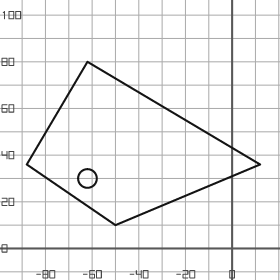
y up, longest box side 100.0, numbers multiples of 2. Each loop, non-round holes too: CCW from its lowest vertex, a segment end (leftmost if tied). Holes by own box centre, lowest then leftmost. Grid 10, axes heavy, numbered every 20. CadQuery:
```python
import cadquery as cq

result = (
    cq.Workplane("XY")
    .moveTo(-50.0, 10.0)
    .lineTo(12.0, 36.0)
    .lineTo(-62.0, 80.0)
    .lineTo(-88.0, 36.0)
    .close()
    .moveTo(-62.0, 30.0)
    .circle(4.0)
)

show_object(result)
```